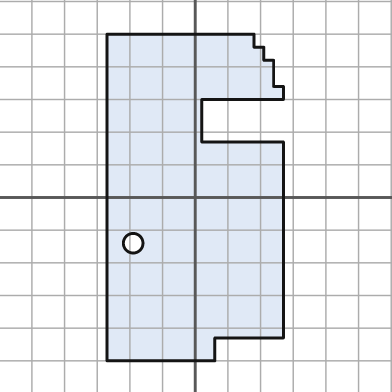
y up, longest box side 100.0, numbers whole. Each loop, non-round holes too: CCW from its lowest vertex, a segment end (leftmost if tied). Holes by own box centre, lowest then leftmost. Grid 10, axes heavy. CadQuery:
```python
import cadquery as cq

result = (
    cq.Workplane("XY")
    .moveTo(-27.0, -50.0)
    .lineTo(6.0, -50.0)
    .lineTo(6.0, -43.0)
    .lineTo(27.0, -43.0)
    .lineTo(27.0, 17.0)
    .lineTo(2.0, 17.0)
    .lineTo(2.0, 30.0)
    .lineTo(27.0, 30.0)
    .lineTo(27.0, 34.0)
    .lineTo(24.0, 34.0)
    .lineTo(24.0, 42.0)
    .lineTo(21.0, 42.0)
    .lineTo(21.0, 46.0)
    .lineTo(18.0, 46.0)
    .lineTo(18.0, 50.0)
    .lineTo(-27.0, 50.0)
    .close()
    .moveTo(-19.0, -14.0)
    .circle(3.0)
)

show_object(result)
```